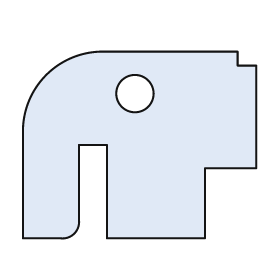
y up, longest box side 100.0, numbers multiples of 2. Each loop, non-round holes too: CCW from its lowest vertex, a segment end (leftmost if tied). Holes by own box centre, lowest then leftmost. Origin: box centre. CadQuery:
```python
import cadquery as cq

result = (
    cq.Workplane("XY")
    .moveTo(-50.0, -40.0)
    .lineTo(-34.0, -40.0)
    .threePointArc((-28.0, -38.0), (-26.0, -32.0))
    .lineTo(-26.0, 0.0)
    .lineTo(-14.0, 0.0)
    .lineTo(-14.0, -40.0)
    .lineTo(28.0, -40.0)
    .lineTo(28.0, -10.0)
    .lineTo(50.0, -10.0)
    .lineTo(50.0, 34.0)
    .lineTo(42.0, 34.0)
    .lineTo(42.0, 40.0)
    .lineTo(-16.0, 40.0)
    .threePointArc((-40.0, 30.0), (-50.0, 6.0))
    .close()
    .moveTo(-2.0, 22.0)
    .circle(8.0)
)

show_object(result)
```